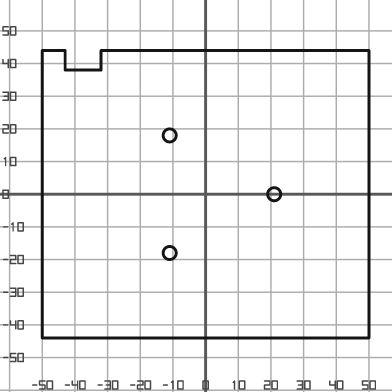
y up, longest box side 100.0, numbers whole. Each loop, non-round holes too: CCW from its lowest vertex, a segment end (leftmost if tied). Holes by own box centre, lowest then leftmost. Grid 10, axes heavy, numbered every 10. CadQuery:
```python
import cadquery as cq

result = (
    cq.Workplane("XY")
    .moveTo(-50.0, -44.0)
    .lineTo(50.0, -44.0)
    .lineTo(50.0, 44.0)
    .lineTo(-32.0, 44.0)
    .lineTo(-32.0, 38.0)
    .lineTo(-43.0, 38.0)
    .lineTo(-43.0, 44.0)
    .lineTo(-50.0, 44.0)
    .close()
    .moveTo(-11.0, -18.0)
    .circle(2.0)
    .moveTo(21.0, 0.0)
    .circle(2.0)
    .moveTo(-11.0, 18.0)
    .circle(2.0)
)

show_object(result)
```